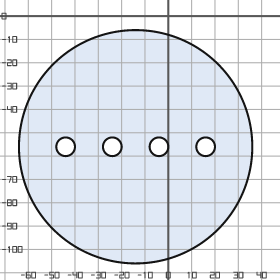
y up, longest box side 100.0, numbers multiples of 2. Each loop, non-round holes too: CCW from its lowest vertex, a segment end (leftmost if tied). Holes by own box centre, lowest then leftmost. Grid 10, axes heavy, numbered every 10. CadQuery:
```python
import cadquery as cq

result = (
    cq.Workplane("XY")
    .moveTo(-14.0, -56.0)
    .circle(50.0)
    .moveTo(-44.0, -56.0)
    .circle(4.0)
    .moveTo(-24.0, -56.0)
    .circle(4.0)
    .moveTo(-4.0, -56.0)
    .circle(4.0)
    .moveTo(16.0, -56.0)
    .circle(4.0)
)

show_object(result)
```